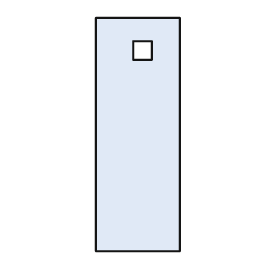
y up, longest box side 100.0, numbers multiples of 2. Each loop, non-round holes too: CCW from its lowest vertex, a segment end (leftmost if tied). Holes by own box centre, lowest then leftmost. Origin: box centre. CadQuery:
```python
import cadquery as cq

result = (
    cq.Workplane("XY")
    .moveTo(-18.0, -50.0)
    .lineTo(18.0, -50.0)
    .lineTo(18.0, 50.0)
    .lineTo(-18.0, 50.0)
    .close()
    .moveTo(-2.0, 32.0)
    .lineTo(6.0, 32.0)
    .lineTo(6.0, 40.0)
    .lineTo(-2.0, 40.0)
    .close()
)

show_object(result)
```